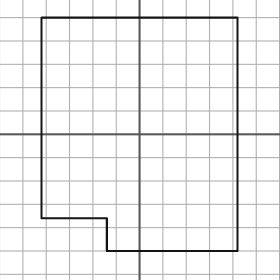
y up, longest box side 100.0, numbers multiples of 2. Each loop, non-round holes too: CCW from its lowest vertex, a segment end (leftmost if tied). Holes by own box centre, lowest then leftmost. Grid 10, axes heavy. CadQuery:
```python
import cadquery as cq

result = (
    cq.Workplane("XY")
    .moveTo(-14.0, -50.0)
    .lineTo(42.0, -50.0)
    .lineTo(42.0, 50.0)
    .lineTo(-42.0, 50.0)
    .lineTo(-42.0, -36.0)
    .lineTo(-14.0, -36.0)
    .close()
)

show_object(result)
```